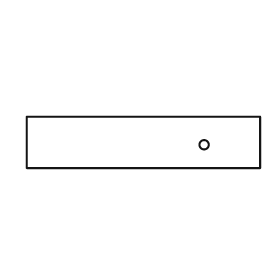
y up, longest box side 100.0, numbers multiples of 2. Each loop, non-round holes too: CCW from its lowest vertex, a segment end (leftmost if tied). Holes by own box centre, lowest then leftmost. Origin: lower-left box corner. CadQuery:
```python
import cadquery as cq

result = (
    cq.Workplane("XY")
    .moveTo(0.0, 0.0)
    .lineTo(100.0, 0.0)
    .lineTo(100.0, 22.0)
    .lineTo(0.0, 22.0)
    .close()
    .moveTo(76.0, 10.0)
    .circle(2.0)
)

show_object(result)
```